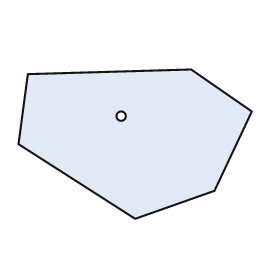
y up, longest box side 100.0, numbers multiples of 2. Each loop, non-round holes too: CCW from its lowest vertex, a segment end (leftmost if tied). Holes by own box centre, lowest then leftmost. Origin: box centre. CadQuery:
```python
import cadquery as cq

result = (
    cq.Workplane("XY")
    .moveTo(0.0, -32.0)
    .lineTo(34.0, -20.0)
    .lineTo(50.0, 14.0)
    .lineTo(24.0, 32.0)
    .lineTo(-46.0, 30.0)
    .lineTo(-50.0, 0.0)
    .close()
    .moveTo(-6.0, 12.0)
    .circle(2.0)
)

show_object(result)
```